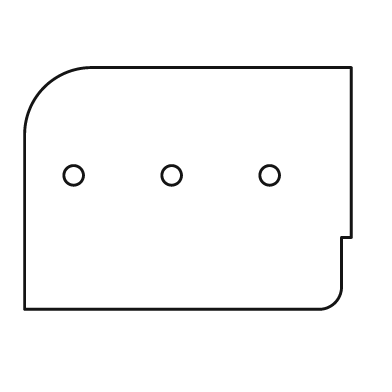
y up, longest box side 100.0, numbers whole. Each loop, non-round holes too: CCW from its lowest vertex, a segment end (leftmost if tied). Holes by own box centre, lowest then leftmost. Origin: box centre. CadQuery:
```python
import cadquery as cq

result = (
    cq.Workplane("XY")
    .moveTo(-50.0, -37.0)
    .lineTo(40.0, -37.0)
    .threePointArc((45.0, -35.0), (47.0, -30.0))
    .lineTo(47.0, -15.0)
    .lineTo(50.0, -15.0)
    .lineTo(50.0, 37.0)
    .lineTo(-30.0, 37.0)
    .threePointArc((-44.0, 31.0), (-50.0, 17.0))
    .close()
    .moveTo(-35.0, 4.0)
    .circle(3.0)
    .moveTo(-5.0, 4.0)
    .circle(3.0)
    .moveTo(25.0, 4.0)
    .circle(3.0)
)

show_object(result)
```